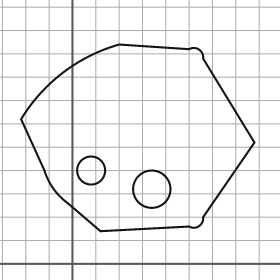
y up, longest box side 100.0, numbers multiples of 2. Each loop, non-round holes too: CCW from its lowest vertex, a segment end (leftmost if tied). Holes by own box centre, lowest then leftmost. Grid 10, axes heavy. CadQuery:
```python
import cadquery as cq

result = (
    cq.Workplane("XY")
    .moveTo(12.0, 14.0)
    .lineTo(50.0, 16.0)
    .threePointArc((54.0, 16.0), (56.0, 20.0))
    .lineTo(78.0, 52.0)
    .lineTo(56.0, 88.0)
    .threePointArc((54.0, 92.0), (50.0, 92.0))
    .lineTo(20.0, 94.0)
    .threePointArc((-4.0, 82.0), (-22.0, 62.0))
    .lineTo(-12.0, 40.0)
    .threePointArc((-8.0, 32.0), (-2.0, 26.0))
    .close()
    .moveTo(34.0, 32.0)
    .circle(8.0)
    .moveTo(8.0, 40.0)
    .circle(6.0)
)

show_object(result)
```